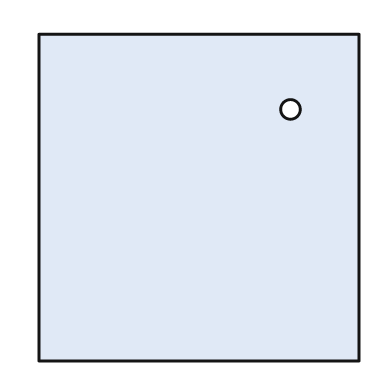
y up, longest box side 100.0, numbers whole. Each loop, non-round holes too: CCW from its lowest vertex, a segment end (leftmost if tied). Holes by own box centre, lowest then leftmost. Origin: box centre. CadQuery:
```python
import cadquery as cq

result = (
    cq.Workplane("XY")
    .moveTo(-49.0, -50.0)
    .lineTo(49.0, -50.0)
    .lineTo(49.0, 50.0)
    .lineTo(-49.0, 50.0)
    .close()
    .moveTo(28.0, 27.0)
    .circle(3.0)
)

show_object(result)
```